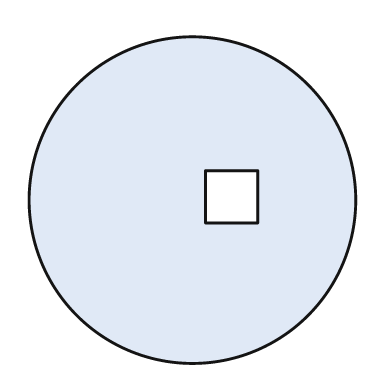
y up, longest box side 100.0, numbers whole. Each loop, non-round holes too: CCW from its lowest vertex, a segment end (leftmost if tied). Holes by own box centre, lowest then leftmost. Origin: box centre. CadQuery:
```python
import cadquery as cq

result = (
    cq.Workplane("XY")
    .moveTo(0.0, 0.0)
    .circle(50.0)
    .moveTo(4.0, -7.0)
    .lineTo(20.0, -7.0)
    .lineTo(20.0, 9.0)
    .lineTo(4.0, 9.0)
    .close()
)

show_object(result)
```